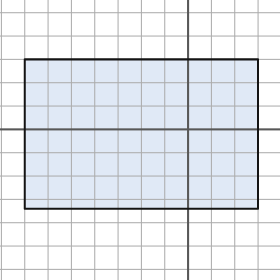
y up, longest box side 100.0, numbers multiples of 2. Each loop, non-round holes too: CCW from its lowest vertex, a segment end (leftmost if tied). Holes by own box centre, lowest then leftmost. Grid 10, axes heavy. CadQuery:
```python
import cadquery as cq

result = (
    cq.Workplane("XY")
    .moveTo(-70.0, -34.0)
    .lineTo(30.0, -34.0)
    .lineTo(30.0, 30.0)
    .lineTo(-70.0, 30.0)
    .close()
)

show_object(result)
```